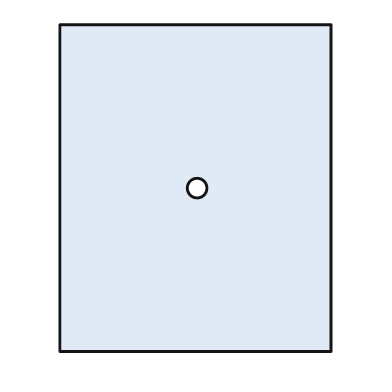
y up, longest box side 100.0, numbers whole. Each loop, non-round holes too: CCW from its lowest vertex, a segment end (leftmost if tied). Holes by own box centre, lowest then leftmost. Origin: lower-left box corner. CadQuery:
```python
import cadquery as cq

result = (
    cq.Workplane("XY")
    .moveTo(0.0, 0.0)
    .lineTo(83.0, 0.0)
    .lineTo(83.0, 100.0)
    .lineTo(0.0, 100.0)
    .close()
    .moveTo(42.0, 50.0)
    .circle(3.0)
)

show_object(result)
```